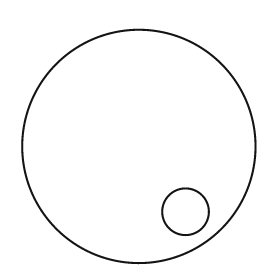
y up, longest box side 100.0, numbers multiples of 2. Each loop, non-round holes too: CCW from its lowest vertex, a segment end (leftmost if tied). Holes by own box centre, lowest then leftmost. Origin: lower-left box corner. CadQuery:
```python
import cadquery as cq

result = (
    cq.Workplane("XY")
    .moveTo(50.0, 50.0)
    .circle(50.0)
    .moveTo(70.0, 22.0)
    .circle(10.0)
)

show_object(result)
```